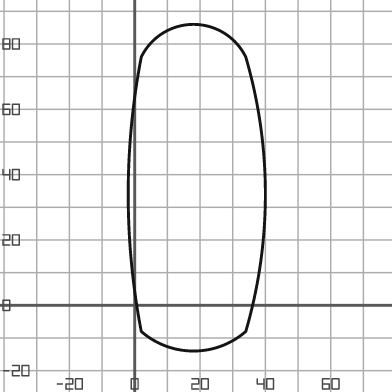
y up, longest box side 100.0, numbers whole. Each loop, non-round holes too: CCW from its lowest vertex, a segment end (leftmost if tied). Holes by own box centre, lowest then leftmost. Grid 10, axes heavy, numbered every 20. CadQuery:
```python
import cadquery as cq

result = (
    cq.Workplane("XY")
    .moveTo(2.0, -8.0)
    .threePointArc((18.0, -14.0), (34.0, -8.0))
    .threePointArc((40.0, 34.0), (34.0, 76.0))
    .threePointArc((18.0, 86.0), (2.0, 76.0))
    .threePointArc((-2.0, 34.0), (2.0, -8.0))
    .close()
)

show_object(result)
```